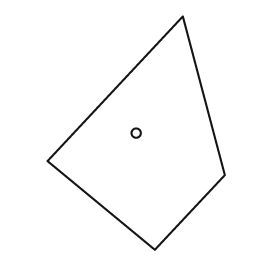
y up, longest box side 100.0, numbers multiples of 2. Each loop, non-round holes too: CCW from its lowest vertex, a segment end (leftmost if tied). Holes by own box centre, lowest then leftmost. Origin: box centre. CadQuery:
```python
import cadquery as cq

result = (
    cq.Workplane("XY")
    .moveTo(8.0, -50.0)
    .lineTo(38.0, -18.0)
    .lineTo(20.0, 50.0)
    .lineTo(-38.0, -12.0)
    .close()
    .moveTo(0.0, 0.0)
    .circle(2.0)
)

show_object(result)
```